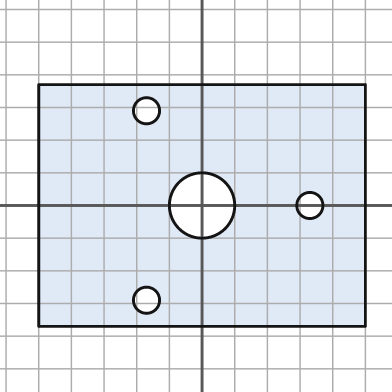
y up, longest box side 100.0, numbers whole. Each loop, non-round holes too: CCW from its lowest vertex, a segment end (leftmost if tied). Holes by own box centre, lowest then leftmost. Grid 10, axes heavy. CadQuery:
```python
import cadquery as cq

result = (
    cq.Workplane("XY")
    .moveTo(-50.0, -37.0)
    .lineTo(50.0, -37.0)
    .lineTo(50.0, 37.0)
    .lineTo(-50.0, 37.0)
    .close()
    .moveTo(-17.0, -29.0)
    .circle(4.0)
    .moveTo(0.0, 0.0)
    .circle(10.0)
    .moveTo(33.0, 0.0)
    .circle(4.0)
    .moveTo(-17.0, 29.0)
    .circle(4.0)
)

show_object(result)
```